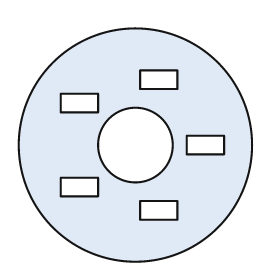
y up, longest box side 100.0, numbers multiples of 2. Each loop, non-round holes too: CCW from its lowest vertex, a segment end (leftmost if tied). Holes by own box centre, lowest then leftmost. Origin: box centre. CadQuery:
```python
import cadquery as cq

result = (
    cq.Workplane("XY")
    .moveTo(0.0, 0.0)
    .circle(50.0)
    .moveTo(2.0, -32.0)
    .lineTo(18.0, -32.0)
    .lineTo(18.0, -24.0)
    .lineTo(2.0, -24.0)
    .close()
    .moveTo(-32.0, -22.0)
    .lineTo(-16.0, -22.0)
    .lineTo(-16.0, -14.0)
    .lineTo(-32.0, -14.0)
    .close()
    .moveTo(0.0, 0.0)
    .circle(16.0)
    .moveTo(22.0, -4.0)
    .lineTo(38.0, -4.0)
    .lineTo(38.0, 4.0)
    .lineTo(22.0, 4.0)
    .close()
    .moveTo(-32.0, 14.0)
    .lineTo(-16.0, 14.0)
    .lineTo(-16.0, 22.0)
    .lineTo(-32.0, 22.0)
    .close()
    .moveTo(2.0, 24.0)
    .lineTo(18.0, 24.0)
    .lineTo(18.0, 32.0)
    .lineTo(2.0, 32.0)
    .close()
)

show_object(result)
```